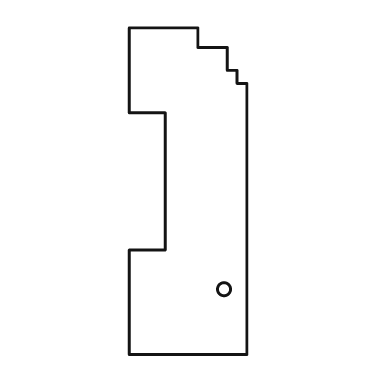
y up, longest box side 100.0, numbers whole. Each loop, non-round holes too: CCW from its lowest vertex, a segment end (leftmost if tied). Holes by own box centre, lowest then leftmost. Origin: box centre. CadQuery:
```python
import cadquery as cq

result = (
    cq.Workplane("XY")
    .moveTo(-18.0, -50.0)
    .lineTo(18.0, -50.0)
    .lineTo(18.0, 33.0)
    .lineTo(15.0, 33.0)
    .lineTo(15.0, 37.0)
    .lineTo(12.0, 37.0)
    .lineTo(12.0, 44.0)
    .lineTo(3.0, 44.0)
    .lineTo(3.0, 50.0)
    .lineTo(-18.0, 50.0)
    .lineTo(-18.0, 24.0)
    .lineTo(-7.0, 24.0)
    .lineTo(-7.0, -18.0)
    .lineTo(-18.0, -18.0)
    .close()
    .moveTo(11.0, -30.0)
    .circle(2.0)
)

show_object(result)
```